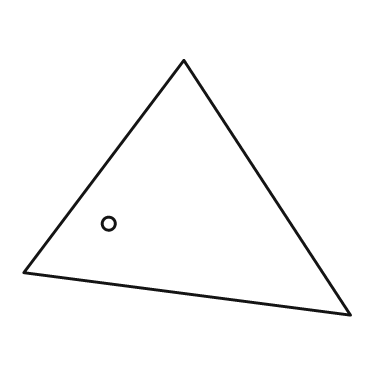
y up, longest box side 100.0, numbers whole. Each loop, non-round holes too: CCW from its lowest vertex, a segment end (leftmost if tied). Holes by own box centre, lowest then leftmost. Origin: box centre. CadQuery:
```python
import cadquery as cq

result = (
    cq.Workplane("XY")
    .moveTo(50.0, -39.0)
    .lineTo(-1.0, 39.0)
    .lineTo(-50.0, -26.0)
    .close()
    .moveTo(-24.0, -11.0)
    .circle(2.0)
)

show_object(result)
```